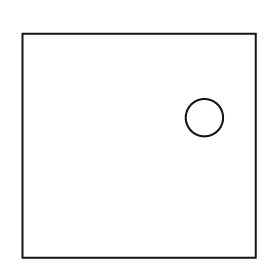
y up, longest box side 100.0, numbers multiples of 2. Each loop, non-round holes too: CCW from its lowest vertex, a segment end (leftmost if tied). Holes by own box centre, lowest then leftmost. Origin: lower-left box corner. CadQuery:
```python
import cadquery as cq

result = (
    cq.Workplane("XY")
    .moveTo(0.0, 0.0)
    .lineTo(100.0, 0.0)
    .lineTo(100.0, 96.0)
    .lineTo(0.0, 96.0)
    .close()
    .moveTo(78.0, 60.0)
    .circle(8.0)
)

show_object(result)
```